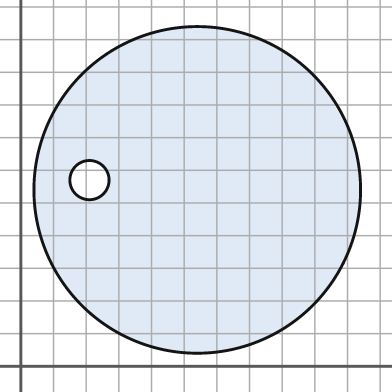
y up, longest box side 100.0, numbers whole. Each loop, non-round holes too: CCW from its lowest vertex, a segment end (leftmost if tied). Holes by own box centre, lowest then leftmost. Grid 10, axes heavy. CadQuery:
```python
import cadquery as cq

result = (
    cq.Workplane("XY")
    .moveTo(54.0, 54.0)
    .circle(50.0)
    .moveTo(21.0, 57.0)
    .circle(6.0)
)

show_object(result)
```